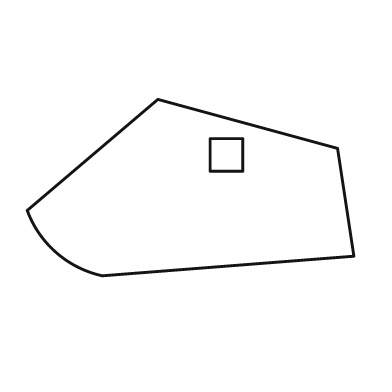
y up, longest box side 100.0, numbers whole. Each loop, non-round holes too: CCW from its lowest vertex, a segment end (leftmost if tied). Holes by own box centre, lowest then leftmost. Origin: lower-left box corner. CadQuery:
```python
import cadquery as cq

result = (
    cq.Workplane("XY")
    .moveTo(23.0, 0.0)
    .lineTo(100.0, 6.0)
    .lineTo(95.0, 39.0)
    .lineTo(40.0, 54.0)
    .lineTo(0.0, 20.0)
    .threePointArc((9.0, 7.0), (23.0, 0.0))
    .close()
    .moveTo(56.0, 32.0)
    .lineTo(66.0, 32.0)
    .lineTo(66.0, 42.0)
    .lineTo(56.0, 42.0)
    .close()
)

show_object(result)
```